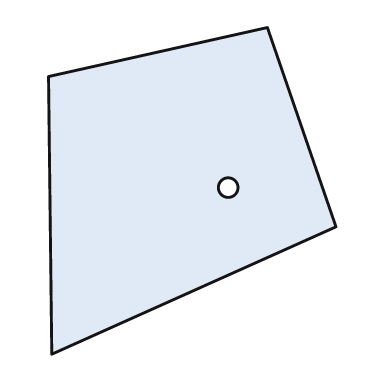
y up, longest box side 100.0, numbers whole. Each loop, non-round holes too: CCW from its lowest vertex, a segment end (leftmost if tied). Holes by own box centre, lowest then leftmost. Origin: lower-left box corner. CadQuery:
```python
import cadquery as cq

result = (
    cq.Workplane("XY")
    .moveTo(1.0, 0.0)
    .lineTo(88.0, 39.0)
    .lineTo(67.0, 100.0)
    .lineTo(0.0, 85.0)
    .close()
    .moveTo(55.0, 51.0)
    .circle(3.0)
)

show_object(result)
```